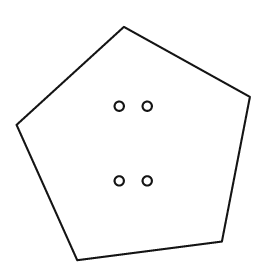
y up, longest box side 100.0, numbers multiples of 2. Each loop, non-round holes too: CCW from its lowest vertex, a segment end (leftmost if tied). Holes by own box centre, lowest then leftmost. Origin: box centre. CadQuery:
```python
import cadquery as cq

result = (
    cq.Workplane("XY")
    .moveTo(-24.0, -50.0)
    .lineTo(38.0, -42.0)
    .lineTo(50.0, 20.0)
    .lineTo(-4.0, 50.0)
    .lineTo(-50.0, 8.0)
    .close()
    .moveTo(-6.0, -16.0)
    .circle(2.0)
    .moveTo(6.0, -16.0)
    .circle(2.0)
    .moveTo(-6.0, 16.0)
    .circle(2.0)
    .moveTo(6.0, 16.0)
    .circle(2.0)
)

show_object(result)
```